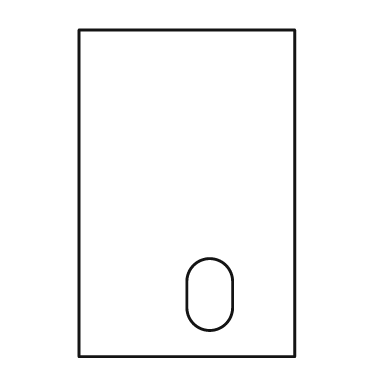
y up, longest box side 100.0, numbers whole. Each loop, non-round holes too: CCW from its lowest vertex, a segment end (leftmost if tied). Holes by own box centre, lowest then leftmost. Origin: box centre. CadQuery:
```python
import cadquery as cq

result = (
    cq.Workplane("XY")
    .moveTo(-33.0, -50.0)
    .lineTo(33.0, -50.0)
    .lineTo(33.0, 50.0)
    .lineTo(-33.0, 50.0)
    .close()
    .moveTo(0.0, -35.0)
    .threePointArc((7.0, -42.0), (14.0, -35.0))
    .lineTo(14.0, -27.0)
    .threePointArc((7.0, -20.0), (0.0, -27.0))
    .close()
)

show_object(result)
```